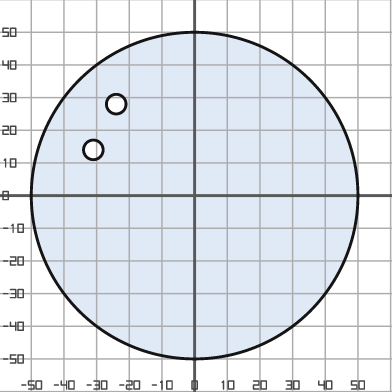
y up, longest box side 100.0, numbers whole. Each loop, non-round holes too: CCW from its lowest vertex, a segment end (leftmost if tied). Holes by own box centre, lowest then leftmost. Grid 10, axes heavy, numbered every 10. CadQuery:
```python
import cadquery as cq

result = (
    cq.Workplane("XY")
    .moveTo(0.0, 0.0)
    .circle(50.0)
    .moveTo(-31.0, 14.0)
    .circle(3.0)
    .moveTo(-24.0, 28.0)
    .circle(3.0)
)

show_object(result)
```